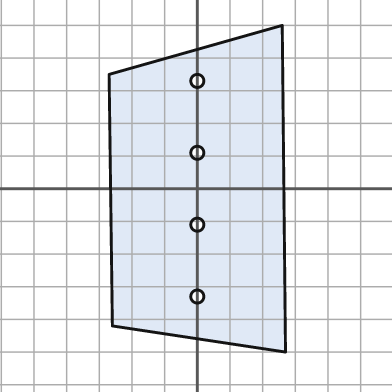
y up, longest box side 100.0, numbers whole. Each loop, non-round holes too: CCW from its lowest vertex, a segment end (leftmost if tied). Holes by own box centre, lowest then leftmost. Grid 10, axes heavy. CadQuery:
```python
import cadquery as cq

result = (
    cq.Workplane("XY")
    .moveTo(27.0, -50.0)
    .lineTo(26.0, 50.0)
    .lineTo(-27.0, 35.0)
    .lineTo(-26.0, -42.0)
    .close()
    .moveTo(0.0, -33.0)
    .circle(2.0)
    .moveTo(0.0, -11.0)
    .circle(2.0)
    .moveTo(0.0, 11.0)
    .circle(2.0)
    .moveTo(0.0, 33.0)
    .circle(2.0)
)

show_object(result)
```